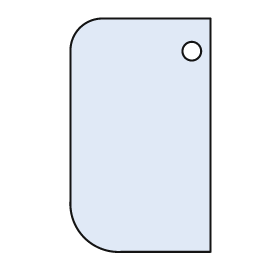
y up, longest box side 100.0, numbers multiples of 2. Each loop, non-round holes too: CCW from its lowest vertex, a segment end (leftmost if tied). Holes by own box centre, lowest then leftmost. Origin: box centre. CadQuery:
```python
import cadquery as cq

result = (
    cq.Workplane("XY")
    .moveTo(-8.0, -50.0)
    .lineTo(30.0, -50.0)
    .lineTo(30.0, 50.0)
    .lineTo(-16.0, 50.0)
    .threePointArc((-26.0, 46.0), (-30.0, 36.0))
    .lineTo(-30.0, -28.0)
    .threePointArc((-24.0, -44.0), (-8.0, -50.0))
    .close()
    .moveTo(22.0, 36.0)
    .circle(4.0)
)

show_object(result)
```